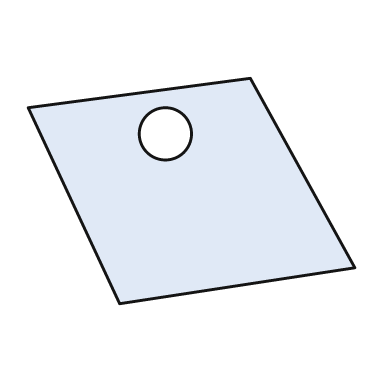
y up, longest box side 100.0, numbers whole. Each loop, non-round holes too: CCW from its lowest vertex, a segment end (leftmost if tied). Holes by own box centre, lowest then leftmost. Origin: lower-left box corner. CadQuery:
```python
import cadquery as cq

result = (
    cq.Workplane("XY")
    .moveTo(28.0, 0.0)
    .lineTo(100.0, 11.0)
    .lineTo(68.0, 69.0)
    .lineTo(0.0, 60.0)
    .close()
    .moveTo(42.0, 52.0)
    .circle(8.0)
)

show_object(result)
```